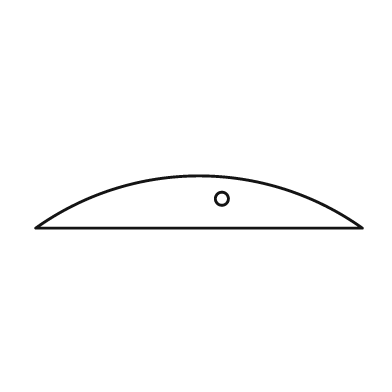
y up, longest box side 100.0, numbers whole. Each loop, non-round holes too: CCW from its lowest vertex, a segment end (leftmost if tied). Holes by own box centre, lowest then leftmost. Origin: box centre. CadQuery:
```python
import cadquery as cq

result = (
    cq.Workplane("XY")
    .moveTo(-50.0, -8.0)
    .lineTo(50.0, -8.0)
    .threePointArc((0.0, 8.0), (-50.0, -8.0))
    .close()
    .moveTo(7.0, 1.0)
    .circle(2.0)
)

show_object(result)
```